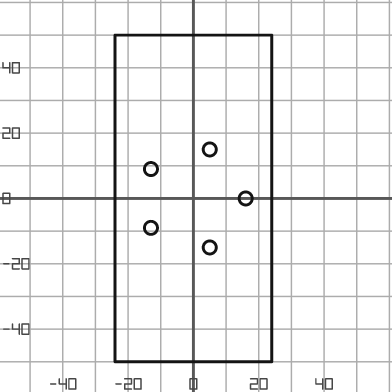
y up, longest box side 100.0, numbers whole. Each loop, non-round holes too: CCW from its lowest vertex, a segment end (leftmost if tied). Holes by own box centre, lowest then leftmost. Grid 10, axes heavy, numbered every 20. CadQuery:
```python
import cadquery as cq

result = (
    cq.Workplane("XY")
    .moveTo(-24.0, -50.0)
    .lineTo(24.0, -50.0)
    .lineTo(24.0, 50.0)
    .lineTo(-24.0, 50.0)
    .close()
    .moveTo(5.0, -15.0)
    .circle(2.0)
    .moveTo(-13.0, -9.0)
    .circle(2.0)
    .moveTo(16.0, 0.0)
    .circle(2.0)
    .moveTo(-13.0, 9.0)
    .circle(2.0)
    .moveTo(5.0, 15.0)
    .circle(2.0)
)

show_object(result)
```